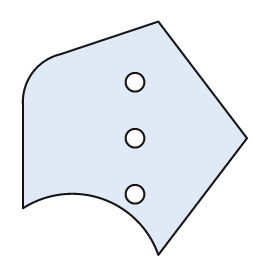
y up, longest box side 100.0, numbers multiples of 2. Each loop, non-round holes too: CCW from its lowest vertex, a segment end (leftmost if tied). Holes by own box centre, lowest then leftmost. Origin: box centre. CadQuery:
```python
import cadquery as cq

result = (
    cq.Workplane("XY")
    .moveTo(10.0, -50.0)
    .lineTo(48.0, 0.0)
    .lineTo(10.0, 50.0)
    .lineTo(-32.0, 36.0)
    .threePointArc((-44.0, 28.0), (-48.0, 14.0))
    .lineTo(-48.0, -30.0)
    .threePointArc((-14.0, -26.0), (10.0, -50.0))
    .close()
    .moveTo(0.0, -24.0)
    .circle(4.0)
    .moveTo(0.0, 0.0)
    .circle(4.0)
    .moveTo(0.0, 24.0)
    .circle(4.0)
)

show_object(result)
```